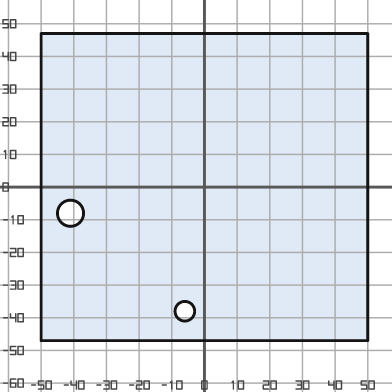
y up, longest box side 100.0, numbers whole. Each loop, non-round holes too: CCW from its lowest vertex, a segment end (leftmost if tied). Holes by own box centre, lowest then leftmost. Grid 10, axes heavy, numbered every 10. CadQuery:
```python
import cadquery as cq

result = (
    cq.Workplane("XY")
    .moveTo(-50.0, -47.0)
    .lineTo(50.0, -47.0)
    .lineTo(50.0, 47.0)
    .lineTo(-50.0, 47.0)
    .close()
    .moveTo(-6.0, -38.0)
    .circle(3.0)
    .moveTo(-41.0, -8.0)
    .circle(4.0)
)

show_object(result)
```